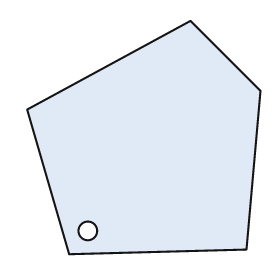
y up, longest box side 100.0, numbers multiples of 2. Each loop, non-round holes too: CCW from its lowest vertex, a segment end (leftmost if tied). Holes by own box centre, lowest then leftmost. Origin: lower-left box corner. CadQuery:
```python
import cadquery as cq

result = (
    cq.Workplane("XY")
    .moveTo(18.0, 0.0)
    .lineTo(94.0, 2.0)
    .lineTo(100.0, 70.0)
    .lineTo(70.0, 100.0)
    .lineTo(0.0, 62.0)
    .close()
    .moveTo(26.0, 10.0)
    .circle(4.0)
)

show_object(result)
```